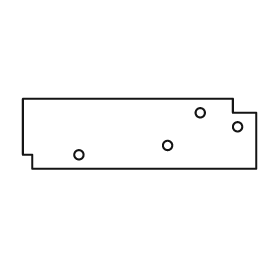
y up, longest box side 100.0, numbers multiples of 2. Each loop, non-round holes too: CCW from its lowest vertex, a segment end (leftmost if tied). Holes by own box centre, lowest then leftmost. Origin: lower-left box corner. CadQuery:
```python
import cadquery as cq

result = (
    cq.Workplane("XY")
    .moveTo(4.0, 0.0)
    .lineTo(100.0, 0.0)
    .lineTo(100.0, 24.0)
    .lineTo(90.0, 24.0)
    .lineTo(90.0, 30.0)
    .lineTo(0.0, 30.0)
    .lineTo(0.0, 6.0)
    .lineTo(4.0, 6.0)
    .close()
    .moveTo(24.0, 6.0)
    .circle(2.0)
    .moveTo(62.0, 10.0)
    .circle(2.0)
    .moveTo(92.0, 18.0)
    .circle(2.0)
    .moveTo(76.0, 24.0)
    .circle(2.0)
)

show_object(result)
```